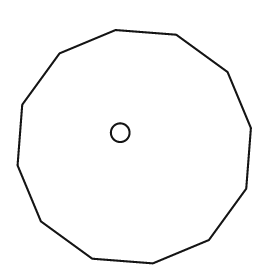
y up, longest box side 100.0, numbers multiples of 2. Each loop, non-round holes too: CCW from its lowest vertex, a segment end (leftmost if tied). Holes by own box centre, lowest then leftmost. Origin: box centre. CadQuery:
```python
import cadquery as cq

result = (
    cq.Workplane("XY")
    .moveTo(8.0, -50.0)
    .lineTo(32.0, -40.0)
    .lineTo(48.0, -18.0)
    .lineTo(50.0, 8.0)
    .lineTo(40.0, 32.0)
    .lineTo(18.0, 48.0)
    .lineTo(-8.0, 50.0)
    .lineTo(-32.0, 40.0)
    .lineTo(-48.0, 18.0)
    .lineTo(-50.0, -8.0)
    .lineTo(-40.0, -32.0)
    .lineTo(-18.0, -48.0)
    .close()
    .moveTo(-6.0, 6.0)
    .circle(4.0)
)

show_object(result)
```